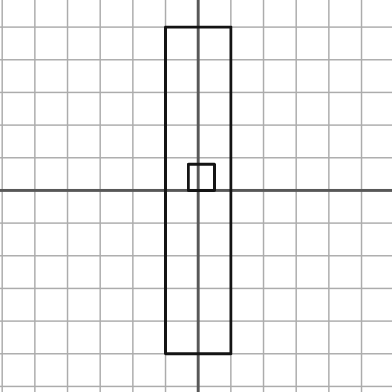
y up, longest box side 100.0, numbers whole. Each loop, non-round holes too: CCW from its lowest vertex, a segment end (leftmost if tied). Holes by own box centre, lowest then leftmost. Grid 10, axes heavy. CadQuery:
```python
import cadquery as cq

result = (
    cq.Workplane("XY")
    .moveTo(-10.0, -50.0)
    .lineTo(10.0, -50.0)
    .lineTo(10.0, 50.0)
    .lineTo(-10.0, 50.0)
    .close()
    .moveTo(-3.0, 0.0)
    .lineTo(5.0, 0.0)
    .lineTo(5.0, 8.0)
    .lineTo(-3.0, 8.0)
    .close()
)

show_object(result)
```